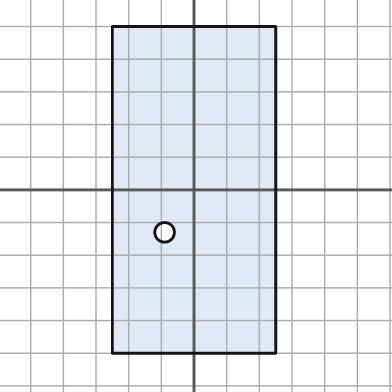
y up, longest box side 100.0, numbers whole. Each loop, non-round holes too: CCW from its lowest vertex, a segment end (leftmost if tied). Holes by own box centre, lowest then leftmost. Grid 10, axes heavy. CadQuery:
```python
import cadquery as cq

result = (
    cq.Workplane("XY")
    .moveTo(-25.0, -50.0)
    .lineTo(25.0, -50.0)
    .lineTo(25.0, 50.0)
    .lineTo(-25.0, 50.0)
    .close()
    .moveTo(-9.0, -13.0)
    .circle(3.0)
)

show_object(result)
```